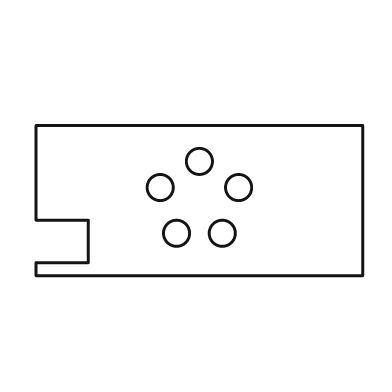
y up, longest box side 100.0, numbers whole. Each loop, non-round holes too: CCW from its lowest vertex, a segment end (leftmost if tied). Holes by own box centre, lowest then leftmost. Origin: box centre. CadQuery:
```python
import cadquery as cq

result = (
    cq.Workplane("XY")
    .moveTo(-50.0, -23.0)
    .lineTo(50.0, -23.0)
    .lineTo(50.0, 23.0)
    .lineTo(-50.0, 23.0)
    .lineTo(-50.0, -6.0)
    .lineTo(-34.0, -6.0)
    .lineTo(-34.0, -19.0)
    .lineTo(-50.0, -19.0)
    .close()
    .moveTo(-7.0, -10.0)
    .circle(4.0)
    .moveTo(7.0, -10.0)
    .circle(4.0)
    .moveTo(-12.0, 4.0)
    .circle(4.0)
    .moveTo(12.0, 4.0)
    .circle(4.0)
    .moveTo(0.0, 12.0)
    .circle(4.0)
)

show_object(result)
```